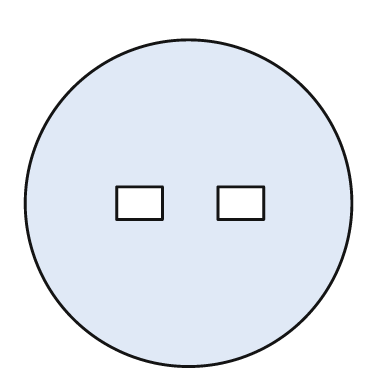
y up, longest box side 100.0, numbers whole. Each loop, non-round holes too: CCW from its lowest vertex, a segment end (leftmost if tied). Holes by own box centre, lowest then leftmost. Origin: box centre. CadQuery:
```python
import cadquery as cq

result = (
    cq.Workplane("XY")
    .moveTo(0.0, 0.0)
    .circle(50.0)
    .moveTo(-22.0, -5.0)
    .lineTo(-8.0, -5.0)
    .lineTo(-8.0, 5.0)
    .lineTo(-22.0, 5.0)
    .close()
    .moveTo(9.0, -5.0)
    .lineTo(23.0, -5.0)
    .lineTo(23.0, 5.0)
    .lineTo(9.0, 5.0)
    .close()
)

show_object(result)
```